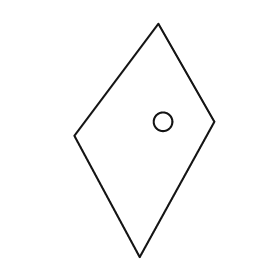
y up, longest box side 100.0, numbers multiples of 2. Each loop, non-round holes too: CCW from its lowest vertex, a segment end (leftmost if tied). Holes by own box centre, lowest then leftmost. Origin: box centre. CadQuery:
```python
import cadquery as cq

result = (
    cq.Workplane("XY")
    .moveTo(-2.0, -50.0)
    .lineTo(30.0, 8.0)
    .lineTo(6.0, 50.0)
    .lineTo(-30.0, 2.0)
    .close()
    .moveTo(8.0, 8.0)
    .circle(4.0)
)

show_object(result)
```